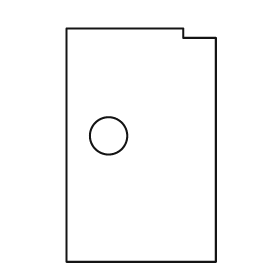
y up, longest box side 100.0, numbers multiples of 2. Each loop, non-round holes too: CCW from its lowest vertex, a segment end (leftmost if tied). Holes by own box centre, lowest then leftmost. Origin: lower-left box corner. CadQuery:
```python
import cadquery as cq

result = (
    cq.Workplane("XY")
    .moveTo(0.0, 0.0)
    .lineTo(64.0, 0.0)
    .lineTo(64.0, 96.0)
    .lineTo(50.0, 96.0)
    .lineTo(50.0, 100.0)
    .lineTo(0.0, 100.0)
    .close()
    .moveTo(18.0, 54.0)
    .circle(8.0)
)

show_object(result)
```